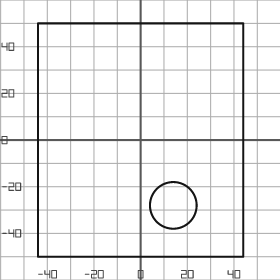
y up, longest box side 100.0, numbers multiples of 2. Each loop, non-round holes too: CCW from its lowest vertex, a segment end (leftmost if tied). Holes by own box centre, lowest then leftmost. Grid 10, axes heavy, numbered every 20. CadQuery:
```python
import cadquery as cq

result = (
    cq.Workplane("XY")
    .moveTo(-44.0, -50.0)
    .lineTo(44.0, -50.0)
    .lineTo(44.0, 50.0)
    .lineTo(-44.0, 50.0)
    .close()
    .moveTo(14.0, -28.0)
    .circle(10.0)
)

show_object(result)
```